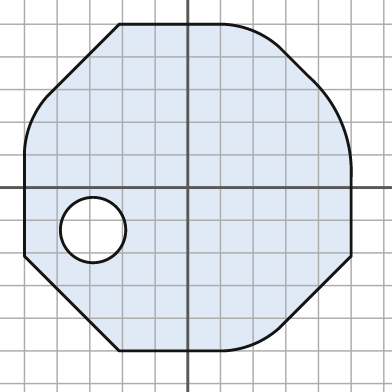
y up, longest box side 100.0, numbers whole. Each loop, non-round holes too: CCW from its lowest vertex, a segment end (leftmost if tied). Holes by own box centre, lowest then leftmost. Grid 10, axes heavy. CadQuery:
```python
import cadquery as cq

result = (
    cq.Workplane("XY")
    .moveTo(-21.0, -50.0)
    .lineTo(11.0, -50.0)
    .threePointArc((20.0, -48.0), (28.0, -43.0))
    .lineTo(50.0, -21.0)
    .lineTo(50.0, 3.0)
    .threePointArc((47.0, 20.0), (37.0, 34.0))
    .lineTo(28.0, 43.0)
    .threePointArc((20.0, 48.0), (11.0, 50.0))
    .lineTo(-21.0, 50.0)
    .lineTo(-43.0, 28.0)
    .threePointArc((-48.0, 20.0), (-50.0, 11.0))
    .lineTo(-50.0, -21.0)
    .close()
    .moveTo(-29.0, -13.0)
    .circle(10.0)
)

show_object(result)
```